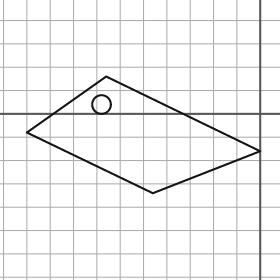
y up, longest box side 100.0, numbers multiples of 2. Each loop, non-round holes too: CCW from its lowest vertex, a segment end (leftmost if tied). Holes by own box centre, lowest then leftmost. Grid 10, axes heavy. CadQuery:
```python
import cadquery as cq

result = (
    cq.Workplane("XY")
    .moveTo(-46.0, -34.0)
    .lineTo(0.0, -16.0)
    .lineTo(-66.0, 16.0)
    .lineTo(-100.0, -8.0)
    .close()
    .moveTo(-68.0, 4.0)
    .circle(4.0)
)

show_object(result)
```